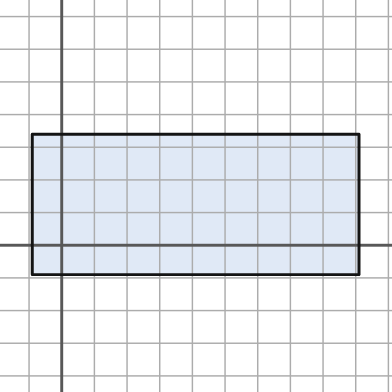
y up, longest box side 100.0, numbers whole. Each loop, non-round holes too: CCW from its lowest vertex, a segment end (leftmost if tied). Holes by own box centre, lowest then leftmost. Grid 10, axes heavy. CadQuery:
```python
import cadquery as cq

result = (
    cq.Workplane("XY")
    .moveTo(-9.0, -9.0)
    .lineTo(91.0, -9.0)
    .lineTo(91.0, 34.0)
    .lineTo(-9.0, 34.0)
    .close()
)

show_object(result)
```